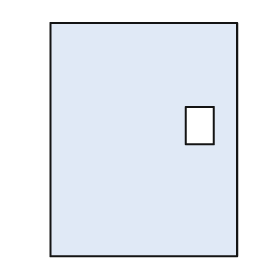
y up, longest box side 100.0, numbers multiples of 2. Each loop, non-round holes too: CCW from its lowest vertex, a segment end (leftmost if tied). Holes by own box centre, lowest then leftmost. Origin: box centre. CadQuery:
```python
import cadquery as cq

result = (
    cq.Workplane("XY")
    .moveTo(-40.0, -50.0)
    .lineTo(40.0, -50.0)
    .lineTo(40.0, 50.0)
    .lineTo(-40.0, 50.0)
    .close()
    .moveTo(18.0, -2.0)
    .lineTo(30.0, -2.0)
    .lineTo(30.0, 14.0)
    .lineTo(18.0, 14.0)
    .close()
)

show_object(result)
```